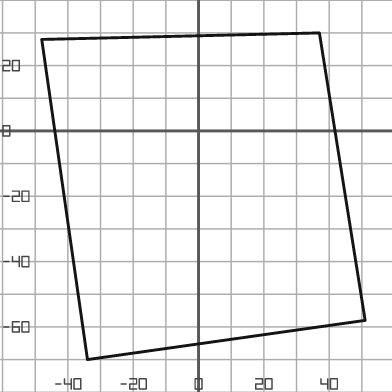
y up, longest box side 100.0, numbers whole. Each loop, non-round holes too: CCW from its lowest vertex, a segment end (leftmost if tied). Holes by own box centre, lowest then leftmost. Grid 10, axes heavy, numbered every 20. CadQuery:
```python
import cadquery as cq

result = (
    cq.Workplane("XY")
    .moveTo(-34.0, -70.0)
    .lineTo(51.0, -58.0)
    .lineTo(37.0, 30.0)
    .lineTo(-48.0, 28.0)
    .close()
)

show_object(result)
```